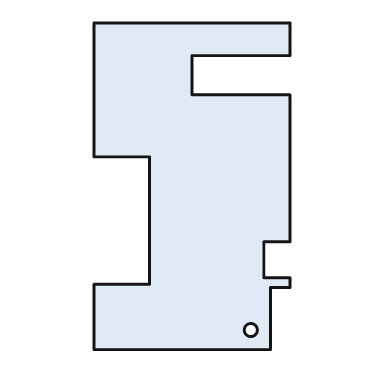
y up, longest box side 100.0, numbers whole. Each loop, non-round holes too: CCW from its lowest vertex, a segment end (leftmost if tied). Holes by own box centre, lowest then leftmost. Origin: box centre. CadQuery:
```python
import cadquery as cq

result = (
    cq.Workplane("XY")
    .moveTo(-30.0, -50.0)
    .lineTo(24.0, -50.0)
    .lineTo(24.0, -31.0)
    .lineTo(30.0, -31.0)
    .lineTo(30.0, -28.0)
    .lineTo(22.0, -28.0)
    .lineTo(22.0, -17.0)
    .lineTo(30.0, -17.0)
    .lineTo(30.0, 28.0)
    .lineTo(0.0, 28.0)
    .lineTo(0.0, 40.0)
    .lineTo(30.0, 40.0)
    .lineTo(30.0, 50.0)
    .lineTo(-30.0, 50.0)
    .lineTo(-30.0, 9.0)
    .lineTo(-13.0, 9.0)
    .lineTo(-13.0, -30.0)
    .lineTo(-30.0, -30.0)
    .close()
    .moveTo(18.0, -44.0)
    .circle(2.0)
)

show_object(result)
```